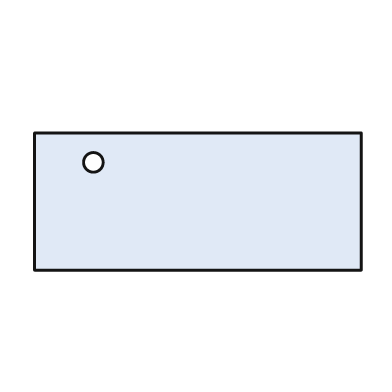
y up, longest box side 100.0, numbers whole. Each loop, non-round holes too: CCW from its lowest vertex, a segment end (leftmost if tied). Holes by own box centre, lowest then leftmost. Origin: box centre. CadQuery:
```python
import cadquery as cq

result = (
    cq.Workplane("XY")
    .moveTo(-50.0, -21.0)
    .lineTo(50.0, -21.0)
    .lineTo(50.0, 21.0)
    .lineTo(-50.0, 21.0)
    .close()
    .moveTo(-32.0, 12.0)
    .circle(3.0)
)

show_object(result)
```